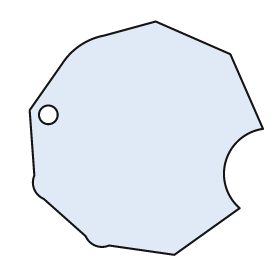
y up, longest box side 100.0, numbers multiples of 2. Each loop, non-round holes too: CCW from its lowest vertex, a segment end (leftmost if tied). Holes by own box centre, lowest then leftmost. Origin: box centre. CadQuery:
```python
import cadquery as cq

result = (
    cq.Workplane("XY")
    .moveTo(12.0, -50.0)
    .lineTo(40.0, -30.0)
    .threePointArc((34.0, -10.0), (50.0, 4.0))
    .lineTo(36.0, 36.0)
    .lineTo(4.0, 50.0)
    .lineTo(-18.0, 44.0)
    .threePointArc((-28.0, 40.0), (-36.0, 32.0))
    .lineTo(-50.0, 12.0)
    .lineTo(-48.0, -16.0)
    .threePointArc((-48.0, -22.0), (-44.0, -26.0))
    .lineTo(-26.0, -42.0)
    .threePointArc((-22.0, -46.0), (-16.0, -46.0))
    .close()
    .moveTo(-42.0, 10.0)
    .circle(4.0)
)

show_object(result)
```